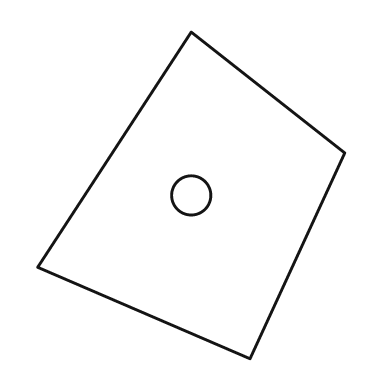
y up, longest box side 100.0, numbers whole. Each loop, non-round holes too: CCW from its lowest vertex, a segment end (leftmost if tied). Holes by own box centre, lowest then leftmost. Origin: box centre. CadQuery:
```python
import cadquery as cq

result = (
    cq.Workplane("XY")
    .moveTo(18.0, -50.0)
    .lineTo(47.0, 13.0)
    .lineTo(0.0, 50.0)
    .lineTo(-47.0, -22.0)
    .close()
    .moveTo(0.0, 0.0)
    .circle(6.0)
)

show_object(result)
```